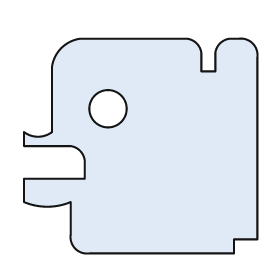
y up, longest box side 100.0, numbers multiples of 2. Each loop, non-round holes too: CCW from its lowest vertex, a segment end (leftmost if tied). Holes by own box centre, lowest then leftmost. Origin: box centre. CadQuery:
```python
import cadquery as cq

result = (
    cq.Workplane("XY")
    .moveTo(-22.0, -46.0)
    .lineTo(40.0, -46.0)
    .lineTo(40.0, -40.0)
    .lineTo(50.0, -40.0)
    .lineTo(50.0, 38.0)
    .threePointArc((48.0, 44.0), (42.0, 46.0))
    .lineTo(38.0, 46.0)
    .threePointArc((34.0, 44.0), (32.0, 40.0))
    .lineTo(32.0, 32.0)
    .lineTo(26.0, 32.0)
    .lineTo(26.0, 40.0)
    .threePointArc((24.0, 44.0), (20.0, 46.0))
    .lineTo(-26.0, 46.0)
    .threePointArc((-34.0, 42.0), (-38.0, 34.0))
    .lineTo(-38.0, 6.0)
    .threePointArc((-44.0, 4.0), (-50.0, 6.0))
    .lineTo(-50.0, 0.0)
    .lineTo(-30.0, 0.0)
    .threePointArc((-26.0, -2.0), (-24.0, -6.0))
    .lineTo(-24.0, -14.0)
    .lineTo(-50.0, -14.0)
    .lineTo(-50.0, -24.0)
    .threePointArc((-40.0, -26.0), (-30.0, -24.0))
    .lineTo(-30.0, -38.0)
    .threePointArc((-28.0, -44.0), (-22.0, -46.0))
    .close()
    .moveTo(-14.0, 16.0)
    .circle(8.0)
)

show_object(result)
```